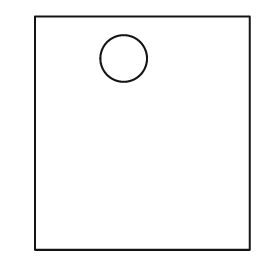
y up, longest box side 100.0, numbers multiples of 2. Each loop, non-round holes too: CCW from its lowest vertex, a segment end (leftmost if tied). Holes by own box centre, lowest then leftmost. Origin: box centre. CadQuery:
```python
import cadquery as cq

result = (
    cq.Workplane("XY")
    .moveTo(-46.0, -50.0)
    .lineTo(46.0, -50.0)
    .lineTo(46.0, 50.0)
    .lineTo(-46.0, 50.0)
    .close()
    .moveTo(-8.0, 32.0)
    .circle(10.0)
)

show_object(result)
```